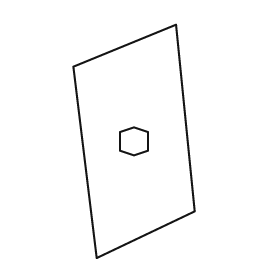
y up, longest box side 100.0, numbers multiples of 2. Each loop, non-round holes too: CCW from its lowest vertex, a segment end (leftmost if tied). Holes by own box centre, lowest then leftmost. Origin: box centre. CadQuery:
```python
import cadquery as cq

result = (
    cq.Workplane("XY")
    .moveTo(-16.0, -50.0)
    .lineTo(26.0, -30.0)
    .lineTo(18.0, 50.0)
    .lineTo(-26.0, 32.0)
    .close()
    .moveTo(0.0, -6.0)
    .lineTo(6.0, -4.0)
    .lineTo(6.0, 4.0)
    .lineTo(0.0, 6.0)
    .lineTo(-6.0, 4.0)
    .lineTo(-6.0, -4.0)
    .close()
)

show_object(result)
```